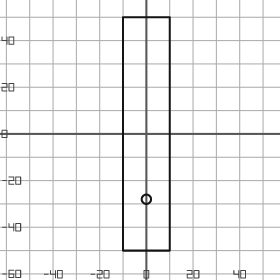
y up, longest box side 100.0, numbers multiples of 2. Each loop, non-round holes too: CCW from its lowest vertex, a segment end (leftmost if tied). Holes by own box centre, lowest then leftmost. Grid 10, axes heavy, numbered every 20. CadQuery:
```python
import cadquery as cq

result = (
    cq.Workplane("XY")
    .moveTo(-10.0, -50.0)
    .lineTo(10.0, -50.0)
    .lineTo(10.0, 50.0)
    .lineTo(-10.0, 50.0)
    .close()
    .moveTo(0.0, -28.0)
    .circle(2.0)
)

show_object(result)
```